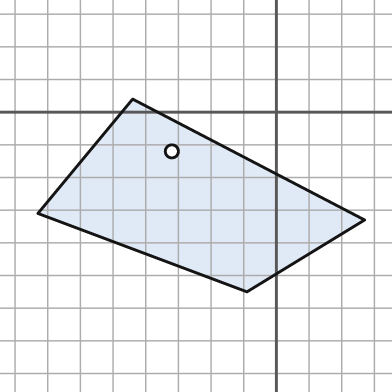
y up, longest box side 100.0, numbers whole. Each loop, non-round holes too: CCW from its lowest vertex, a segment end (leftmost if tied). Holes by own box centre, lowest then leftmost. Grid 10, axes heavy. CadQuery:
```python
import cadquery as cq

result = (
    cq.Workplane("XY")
    .moveTo(-9.0, -55.0)
    .lineTo(27.0, -33.0)
    .lineTo(-44.0, 4.0)
    .lineTo(-73.0, -31.0)
    .close()
    .moveTo(-32.0, -12.0)
    .circle(2.0)
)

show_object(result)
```